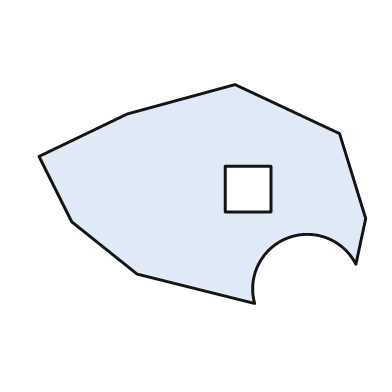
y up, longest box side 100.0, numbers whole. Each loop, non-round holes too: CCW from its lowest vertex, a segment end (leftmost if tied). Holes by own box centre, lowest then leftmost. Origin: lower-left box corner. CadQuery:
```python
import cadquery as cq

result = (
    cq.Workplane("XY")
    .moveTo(66.0, 0.0)
    .threePointArc((76.0, 20.0), (97.0, 12.0))
    .lineTo(100.0, 26.0)
    .lineTo(92.0, 52.0)
    .lineTo(60.0, 67.0)
    .lineTo(27.0, 58.0)
    .lineTo(0.0, 45.0)
    .lineTo(10.0, 25.0)
    .lineTo(30.0, 9.0)
    .close()
    .moveTo(57.0, 28.0)
    .lineTo(71.0, 28.0)
    .lineTo(71.0, 42.0)
    .lineTo(57.0, 42.0)
    .close()
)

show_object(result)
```